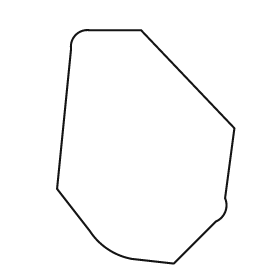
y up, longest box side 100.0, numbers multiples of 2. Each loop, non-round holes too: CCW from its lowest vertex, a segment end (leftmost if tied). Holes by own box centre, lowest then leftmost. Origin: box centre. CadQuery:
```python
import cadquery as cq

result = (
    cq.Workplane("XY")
    .moveTo(12.0, -50.0)
    .lineTo(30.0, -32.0)
    .threePointArc((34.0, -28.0), (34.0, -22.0))
    .lineTo(38.0, 8.0)
    .lineTo(-2.0, 50.0)
    .lineTo(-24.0, 50.0)
    .threePointArc((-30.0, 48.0), (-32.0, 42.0))
    .lineTo(-38.0, -18.0)
    .lineTo(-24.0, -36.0)
    .threePointArc((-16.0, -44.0), (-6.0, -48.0))
    .close()
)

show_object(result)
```